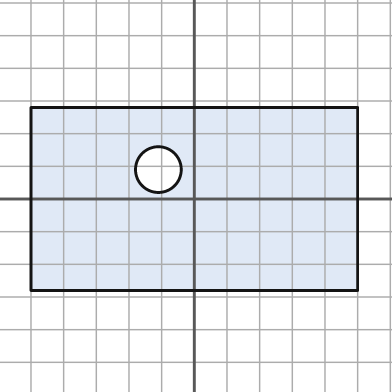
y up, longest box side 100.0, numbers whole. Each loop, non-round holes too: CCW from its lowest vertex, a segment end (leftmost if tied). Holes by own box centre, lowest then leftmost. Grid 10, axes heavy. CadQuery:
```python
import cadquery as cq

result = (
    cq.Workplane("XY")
    .moveTo(-50.0, -28.0)
    .lineTo(50.0, -28.0)
    .lineTo(50.0, 28.0)
    .lineTo(-50.0, 28.0)
    .close()
    .moveTo(-11.0, 9.0)
    .circle(7.0)
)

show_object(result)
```